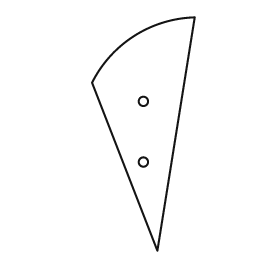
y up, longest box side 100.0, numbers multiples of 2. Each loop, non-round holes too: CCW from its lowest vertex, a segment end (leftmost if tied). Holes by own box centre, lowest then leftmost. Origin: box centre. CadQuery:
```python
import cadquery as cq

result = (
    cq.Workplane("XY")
    .moveTo(6.0, -50.0)
    .lineTo(22.0, 50.0)
    .threePointArc((-4.0, 42.0), (-22.0, 22.0))
    .close()
    .moveTo(0.0, -12.0)
    .circle(2.0)
    .moveTo(0.0, 14.0)
    .circle(2.0)
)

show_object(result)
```